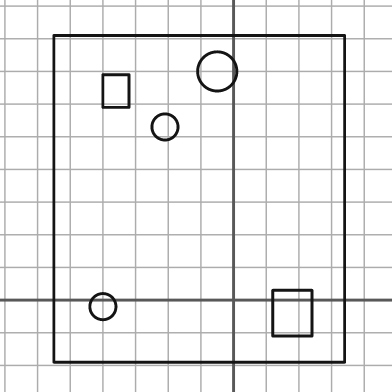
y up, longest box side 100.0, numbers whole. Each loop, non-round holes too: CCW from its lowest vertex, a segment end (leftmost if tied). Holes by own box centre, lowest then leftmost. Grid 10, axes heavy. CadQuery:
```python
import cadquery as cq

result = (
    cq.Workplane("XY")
    .moveTo(-55.0, -19.0)
    .lineTo(34.0, -19.0)
    .lineTo(34.0, 81.0)
    .lineTo(-55.0, 81.0)
    .close()
    .moveTo(12.0, -11.0)
    .lineTo(24.0, -11.0)
    .lineTo(24.0, 3.0)
    .lineTo(12.0, 3.0)
    .close()
    .moveTo(-40.0, -2.0)
    .circle(4.0)
    .moveTo(-21.0, 53.0)
    .circle(4.0)
    .moveTo(-40.0, 59.0)
    .lineTo(-32.0, 59.0)
    .lineTo(-32.0, 69.0)
    .lineTo(-40.0, 69.0)
    .close()
    .moveTo(-5.0, 70.0)
    .circle(6.0)
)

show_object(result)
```